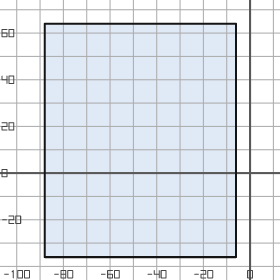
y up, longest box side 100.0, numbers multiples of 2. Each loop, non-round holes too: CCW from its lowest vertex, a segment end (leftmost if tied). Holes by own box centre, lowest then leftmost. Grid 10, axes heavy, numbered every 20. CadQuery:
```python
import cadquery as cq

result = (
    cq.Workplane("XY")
    .moveTo(-88.0, -36.0)
    .lineTo(-6.0, -36.0)
    .lineTo(-6.0, 64.0)
    .lineTo(-88.0, 64.0)
    .close()
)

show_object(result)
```